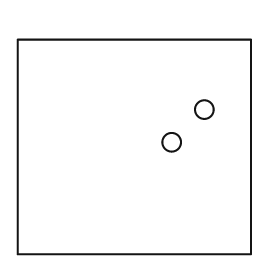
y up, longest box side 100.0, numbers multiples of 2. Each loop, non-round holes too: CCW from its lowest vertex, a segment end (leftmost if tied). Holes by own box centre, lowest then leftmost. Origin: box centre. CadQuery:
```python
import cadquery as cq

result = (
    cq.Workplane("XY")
    .moveTo(-50.0, -46.0)
    .lineTo(50.0, -46.0)
    .lineTo(50.0, 46.0)
    .lineTo(-50.0, 46.0)
    .close()
    .moveTo(16.0, 2.0)
    .circle(4.0)
    .moveTo(30.0, 16.0)
    .circle(4.0)
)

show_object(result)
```